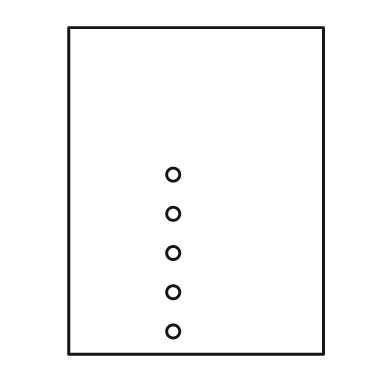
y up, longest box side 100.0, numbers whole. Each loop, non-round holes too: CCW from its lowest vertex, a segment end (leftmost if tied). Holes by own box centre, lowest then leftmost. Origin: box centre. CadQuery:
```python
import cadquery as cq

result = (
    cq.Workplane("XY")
    .moveTo(-39.0, -50.0)
    .lineTo(39.0, -50.0)
    .lineTo(39.0, 50.0)
    .lineTo(-39.0, 50.0)
    .close()
    .moveTo(-7.0, -43.0)
    .circle(2.0)
    .moveTo(-7.0, -31.0)
    .circle(2.0)
    .moveTo(-7.0, -19.0)
    .circle(2.0)
    .moveTo(-7.0, -7.0)
    .circle(2.0)
    .moveTo(-7.0, 5.0)
    .circle(2.0)
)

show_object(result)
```